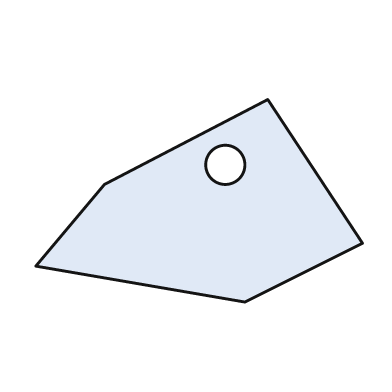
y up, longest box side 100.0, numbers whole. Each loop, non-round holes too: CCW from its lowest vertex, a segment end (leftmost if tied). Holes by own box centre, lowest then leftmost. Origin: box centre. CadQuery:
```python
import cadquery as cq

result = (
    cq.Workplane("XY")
    .moveTo(14.0, -31.0)
    .lineTo(50.0, -13.0)
    .lineTo(21.0, 31.0)
    .lineTo(-29.0, 5.0)
    .lineTo(-50.0, -20.0)
    .close()
    .moveTo(8.0, 11.0)
    .circle(6.0)
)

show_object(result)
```